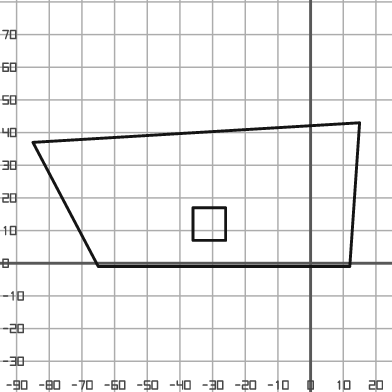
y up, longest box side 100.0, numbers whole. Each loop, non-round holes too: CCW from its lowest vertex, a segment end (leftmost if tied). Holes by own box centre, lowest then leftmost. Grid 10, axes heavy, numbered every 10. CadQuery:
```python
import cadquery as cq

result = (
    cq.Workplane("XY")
    .moveTo(-65.0, -1.0)
    .lineTo(12.0, -1.0)
    .lineTo(15.0, 43.0)
    .lineTo(-85.0, 37.0)
    .close()
    .moveTo(-36.0, 7.0)
    .lineTo(-26.0, 7.0)
    .lineTo(-26.0, 17.0)
    .lineTo(-36.0, 17.0)
    .close()
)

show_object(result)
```